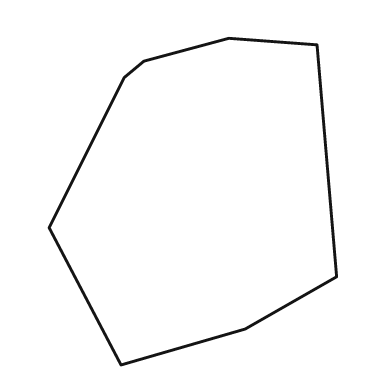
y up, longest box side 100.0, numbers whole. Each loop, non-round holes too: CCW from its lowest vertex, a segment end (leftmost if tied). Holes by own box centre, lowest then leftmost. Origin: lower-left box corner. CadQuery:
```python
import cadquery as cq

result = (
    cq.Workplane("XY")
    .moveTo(22.0, 0.0)
    .lineTo(60.0, 11.0)
    .lineTo(88.0, 27.0)
    .lineTo(82.0, 98.0)
    .lineTo(55.0, 100.0)
    .lineTo(29.0, 93.0)
    .lineTo(23.0, 88.0)
    .lineTo(0.0, 42.0)
    .close()
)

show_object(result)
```